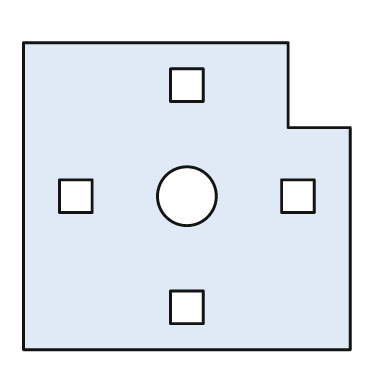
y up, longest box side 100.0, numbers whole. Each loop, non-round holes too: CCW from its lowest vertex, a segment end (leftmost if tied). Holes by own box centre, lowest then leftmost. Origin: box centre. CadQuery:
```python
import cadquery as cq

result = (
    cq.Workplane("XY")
    .moveTo(-50.0, -47.0)
    .lineTo(50.0, -47.0)
    .lineTo(50.0, 21.0)
    .lineTo(31.0, 21.0)
    .lineTo(31.0, 47.0)
    .lineTo(-50.0, 47.0)
    .close()
    .moveTo(-5.0, -39.0)
    .lineTo(5.0, -39.0)
    .lineTo(5.0, -29.0)
    .lineTo(-5.0, -29.0)
    .close()
    .moveTo(-39.0, -5.0)
    .lineTo(-29.0, -5.0)
    .lineTo(-29.0, 5.0)
    .lineTo(-39.0, 5.0)
    .close()
    .moveTo(0.0, 0.0)
    .circle(9.0)
    .moveTo(29.0, -5.0)
    .lineTo(39.0, -5.0)
    .lineTo(39.0, 5.0)
    .lineTo(29.0, 5.0)
    .close()
    .moveTo(-5.0, 29.0)
    .lineTo(5.0, 29.0)
    .lineTo(5.0, 39.0)
    .lineTo(-5.0, 39.0)
    .close()
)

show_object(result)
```